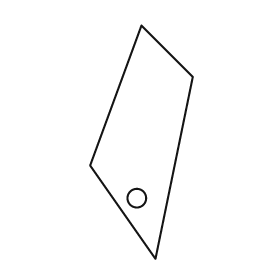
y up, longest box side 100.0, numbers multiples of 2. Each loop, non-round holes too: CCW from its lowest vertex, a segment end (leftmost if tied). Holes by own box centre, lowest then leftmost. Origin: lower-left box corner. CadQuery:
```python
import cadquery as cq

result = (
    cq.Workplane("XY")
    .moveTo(28.0, 0.0)
    .lineTo(44.0, 78.0)
    .lineTo(22.0, 100.0)
    .lineTo(0.0, 40.0)
    .close()
    .moveTo(20.0, 26.0)
    .circle(4.0)
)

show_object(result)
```